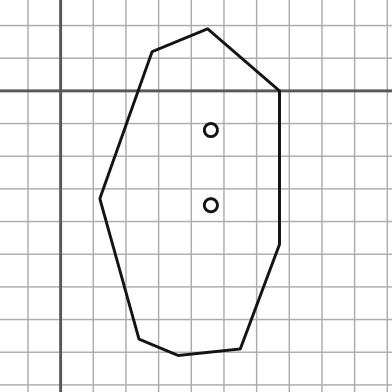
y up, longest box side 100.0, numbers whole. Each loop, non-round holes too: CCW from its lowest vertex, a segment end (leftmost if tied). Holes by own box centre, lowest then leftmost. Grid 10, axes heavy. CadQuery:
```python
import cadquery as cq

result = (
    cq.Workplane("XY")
    .moveTo(36.0, -81.0)
    .lineTo(55.0, -79.0)
    .lineTo(67.0, -47.0)
    .lineTo(67.0, 0.0)
    .lineTo(45.0, 19.0)
    .lineTo(28.0, 12.0)
    .lineTo(12.0, -33.0)
    .lineTo(24.0, -76.0)
    .close()
    .moveTo(46.0, -35.0)
    .circle(2.0)
    .moveTo(46.0, -12.0)
    .circle(2.0)
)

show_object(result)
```